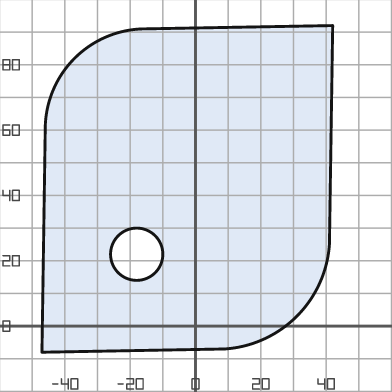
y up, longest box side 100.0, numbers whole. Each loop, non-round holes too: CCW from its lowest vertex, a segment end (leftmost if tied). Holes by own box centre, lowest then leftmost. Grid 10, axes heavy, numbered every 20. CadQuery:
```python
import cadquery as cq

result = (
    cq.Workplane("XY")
    .moveTo(-47.0, -8.0)
    .lineTo(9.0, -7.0)
    .threePointArc((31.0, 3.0), (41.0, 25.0))
    .lineTo(42.0, 92.0)
    .lineTo(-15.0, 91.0)
    .threePointArc((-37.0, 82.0), (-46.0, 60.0))
    .close()
    .moveTo(-18.0, 22.0)
    .circle(8.0)
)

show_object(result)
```